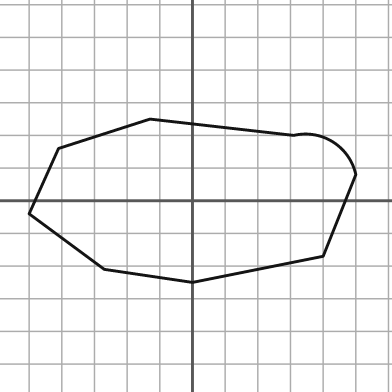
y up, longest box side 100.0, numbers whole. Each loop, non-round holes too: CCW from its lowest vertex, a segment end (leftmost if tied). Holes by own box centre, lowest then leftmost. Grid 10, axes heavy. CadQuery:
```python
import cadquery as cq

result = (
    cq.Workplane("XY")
    .moveTo(0.0, -25.0)
    .lineTo(40.0, -17.0)
    .lineTo(50.0, 8.0)
    .threePointArc((43.0, 18.0), (31.0, 20.0))
    .lineTo(-13.0, 25.0)
    .lineTo(-41.0, 16.0)
    .lineTo(-50.0, -4.0)
    .lineTo(-27.0, -21.0)
    .close()
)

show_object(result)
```